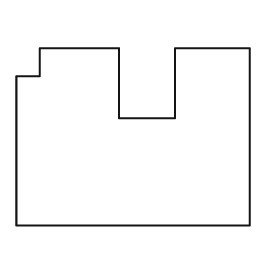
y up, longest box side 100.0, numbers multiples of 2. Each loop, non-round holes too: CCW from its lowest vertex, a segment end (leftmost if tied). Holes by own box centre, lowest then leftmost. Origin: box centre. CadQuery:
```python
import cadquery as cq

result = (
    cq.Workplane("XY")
    .moveTo(-50.0, -38.0)
    .lineTo(50.0, -38.0)
    .lineTo(50.0, 38.0)
    .lineTo(18.0, 38.0)
    .lineTo(18.0, 8.0)
    .lineTo(-6.0, 8.0)
    .lineTo(-6.0, 38.0)
    .lineTo(-40.0, 38.0)
    .lineTo(-40.0, 26.0)
    .lineTo(-50.0, 26.0)
    .close()
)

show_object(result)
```